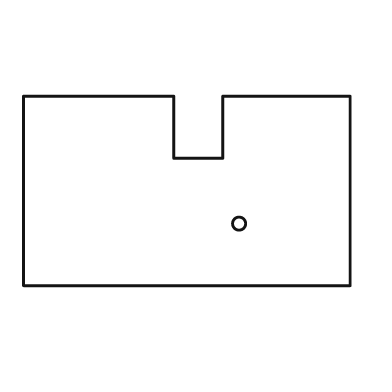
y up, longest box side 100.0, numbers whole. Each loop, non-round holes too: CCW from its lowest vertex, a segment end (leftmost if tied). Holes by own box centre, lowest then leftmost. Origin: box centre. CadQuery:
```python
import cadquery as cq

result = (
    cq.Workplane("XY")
    .moveTo(-50.0, -29.0)
    .lineTo(50.0, -29.0)
    .lineTo(50.0, 29.0)
    .lineTo(11.0, 29.0)
    .lineTo(11.0, 10.0)
    .lineTo(-4.0, 10.0)
    .lineTo(-4.0, 29.0)
    .lineTo(-50.0, 29.0)
    .close()
    .moveTo(16.0, -10.0)
    .circle(2.0)
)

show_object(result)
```